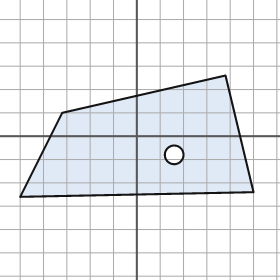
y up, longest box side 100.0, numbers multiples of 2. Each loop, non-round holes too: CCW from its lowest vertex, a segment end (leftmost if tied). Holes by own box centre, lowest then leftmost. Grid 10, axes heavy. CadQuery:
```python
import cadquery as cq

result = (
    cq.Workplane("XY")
    .moveTo(-50.0, -26.0)
    .lineTo(50.0, -24.0)
    .lineTo(38.0, 26.0)
    .lineTo(-32.0, 10.0)
    .close()
    .moveTo(16.0, -8.0)
    .circle(4.0)
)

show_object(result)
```